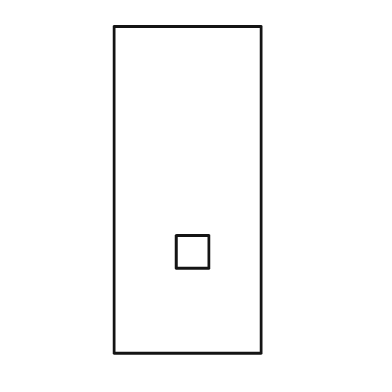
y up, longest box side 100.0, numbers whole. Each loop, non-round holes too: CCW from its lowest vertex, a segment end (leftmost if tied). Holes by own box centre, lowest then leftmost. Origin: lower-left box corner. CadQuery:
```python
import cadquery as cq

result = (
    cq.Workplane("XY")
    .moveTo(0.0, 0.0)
    .lineTo(45.0, 0.0)
    .lineTo(45.0, 100.0)
    .lineTo(0.0, 100.0)
    .close()
    .moveTo(19.0, 26.0)
    .lineTo(29.0, 26.0)
    .lineTo(29.0, 36.0)
    .lineTo(19.0, 36.0)
    .close()
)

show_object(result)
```